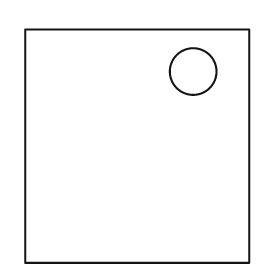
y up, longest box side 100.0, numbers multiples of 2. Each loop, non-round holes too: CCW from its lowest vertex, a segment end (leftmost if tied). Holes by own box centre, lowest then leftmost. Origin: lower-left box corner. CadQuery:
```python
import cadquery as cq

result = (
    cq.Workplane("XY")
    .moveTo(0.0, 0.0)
    .lineTo(96.0, 0.0)
    .lineTo(96.0, 100.0)
    .lineTo(0.0, 100.0)
    .close()
    .moveTo(72.0, 82.0)
    .circle(10.0)
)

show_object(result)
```